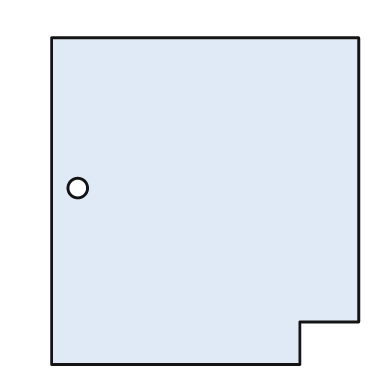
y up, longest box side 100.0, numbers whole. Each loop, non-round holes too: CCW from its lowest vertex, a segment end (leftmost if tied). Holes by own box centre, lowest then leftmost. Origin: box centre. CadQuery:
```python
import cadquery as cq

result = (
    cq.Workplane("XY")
    .moveTo(-47.0, -50.0)
    .lineTo(29.0, -50.0)
    .lineTo(29.0, -37.0)
    .lineTo(47.0, -37.0)
    .lineTo(47.0, 50.0)
    .lineTo(-47.0, 50.0)
    .close()
    .moveTo(-39.0, 4.0)
    .circle(3.0)
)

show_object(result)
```